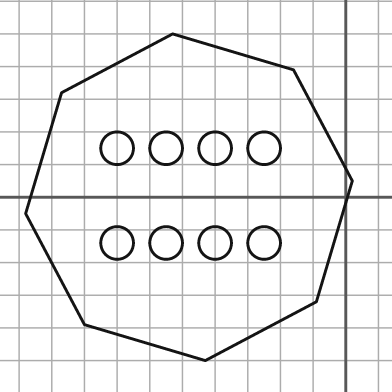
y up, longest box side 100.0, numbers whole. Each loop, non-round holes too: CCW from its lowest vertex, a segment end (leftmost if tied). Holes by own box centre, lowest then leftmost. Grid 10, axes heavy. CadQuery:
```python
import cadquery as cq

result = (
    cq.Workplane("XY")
    .moveTo(-43.0, -50.0)
    .lineTo(-9.0, -32.0)
    .lineTo(2.0, 5.0)
    .lineTo(-16.0, 39.0)
    .lineTo(-53.0, 50.0)
    .lineTo(-87.0, 32.0)
    .lineTo(-98.0, -5.0)
    .lineTo(-80.0, -39.0)
    .close()
    .moveTo(-70.0, -14.0)
    .circle(5.0)
    .moveTo(-55.0, -14.0)
    .circle(5.0)
    .moveTo(-40.0, -14.0)
    .circle(5.0)
    .moveTo(-25.0, -14.0)
    .circle(5.0)
    .moveTo(-70.0, 15.0)
    .circle(5.0)
    .moveTo(-55.0, 15.0)
    .circle(5.0)
    .moveTo(-40.0, 15.0)
    .circle(5.0)
    .moveTo(-25.0, 15.0)
    .circle(5.0)
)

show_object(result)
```